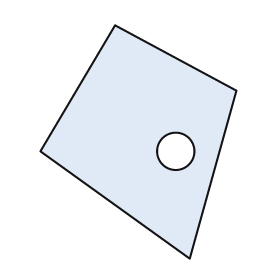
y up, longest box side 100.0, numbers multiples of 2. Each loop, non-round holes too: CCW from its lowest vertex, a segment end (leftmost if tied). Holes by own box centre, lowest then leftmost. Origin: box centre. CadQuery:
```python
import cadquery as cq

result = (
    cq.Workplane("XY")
    .moveTo(22.0, -50.0)
    .lineTo(42.0, 22.0)
    .lineTo(-10.0, 50.0)
    .lineTo(-42.0, -4.0)
    .close()
    .moveTo(16.0, -4.0)
    .circle(8.0)
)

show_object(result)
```